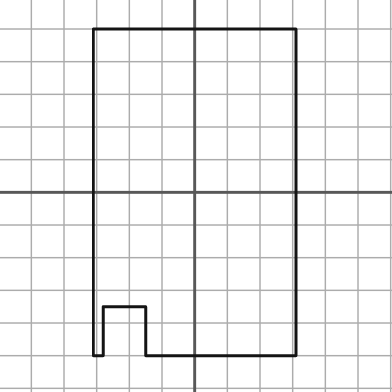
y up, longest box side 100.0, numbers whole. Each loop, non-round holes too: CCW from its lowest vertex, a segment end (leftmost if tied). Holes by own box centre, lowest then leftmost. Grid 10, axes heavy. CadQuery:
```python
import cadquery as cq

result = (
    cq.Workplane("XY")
    .moveTo(-31.0, -50.0)
    .lineTo(-28.0, -50.0)
    .lineTo(-28.0, -35.0)
    .lineTo(-15.0, -35.0)
    .lineTo(-15.0, -50.0)
    .lineTo(31.0, -50.0)
    .lineTo(31.0, 50.0)
    .lineTo(-31.0, 50.0)
    .close()
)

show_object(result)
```